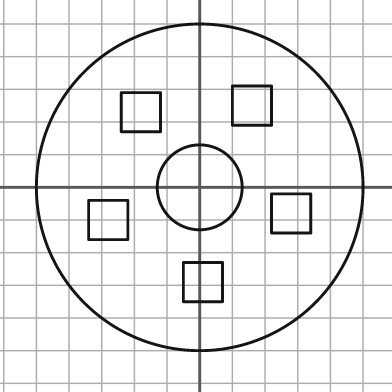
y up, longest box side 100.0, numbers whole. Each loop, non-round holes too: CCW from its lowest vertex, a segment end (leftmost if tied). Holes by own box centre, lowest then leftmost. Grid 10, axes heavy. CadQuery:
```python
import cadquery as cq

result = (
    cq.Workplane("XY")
    .moveTo(0.0, 0.0)
    .circle(50.0)
    .moveTo(-5.0, -35.0)
    .lineTo(7.0, -35.0)
    .lineTo(7.0, -23.0)
    .lineTo(-5.0, -23.0)
    .close()
    .moveTo(-34.0, -16.0)
    .lineTo(-22.0, -16.0)
    .lineTo(-22.0, -4.0)
    .lineTo(-34.0, -4.0)
    .close()
    .moveTo(22.0, -14.0)
    .lineTo(34.0, -14.0)
    .lineTo(34.0, -2.0)
    .lineTo(22.0, -2.0)
    .close()
    .moveTo(0.0, 0.0)
    .circle(13.0)
    .moveTo(-24.0, 17.0)
    .lineTo(-12.0, 17.0)
    .lineTo(-12.0, 29.0)
    .lineTo(-24.0, 29.0)
    .close()
    .moveTo(10.0, 19.0)
    .lineTo(22.0, 19.0)
    .lineTo(22.0, 31.0)
    .lineTo(10.0, 31.0)
    .close()
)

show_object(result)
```